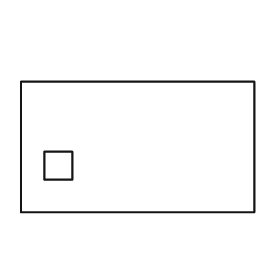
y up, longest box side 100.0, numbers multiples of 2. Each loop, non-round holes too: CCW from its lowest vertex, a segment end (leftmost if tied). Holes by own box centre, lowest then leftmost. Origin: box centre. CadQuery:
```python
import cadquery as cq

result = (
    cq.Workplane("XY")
    .moveTo(-50.0, -28.0)
    .lineTo(50.0, -28.0)
    .lineTo(50.0, 28.0)
    .lineTo(-50.0, 28.0)
    .close()
    .moveTo(-40.0, -14.0)
    .lineTo(-28.0, -14.0)
    .lineTo(-28.0, -2.0)
    .lineTo(-40.0, -2.0)
    .close()
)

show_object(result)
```